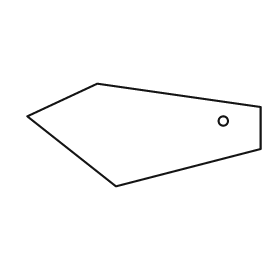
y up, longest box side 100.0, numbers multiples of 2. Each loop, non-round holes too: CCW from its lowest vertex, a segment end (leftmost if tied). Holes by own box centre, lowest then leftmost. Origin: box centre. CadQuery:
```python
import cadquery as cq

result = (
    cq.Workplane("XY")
    .moveTo(-12.0, -22.0)
    .lineTo(50.0, -6.0)
    .lineTo(50.0, 12.0)
    .lineTo(-20.0, 22.0)
    .lineTo(-50.0, 8.0)
    .close()
    .moveTo(34.0, 6.0)
    .circle(2.0)
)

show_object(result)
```